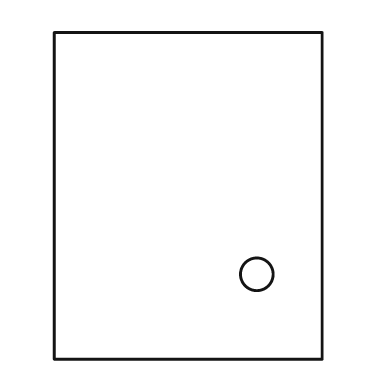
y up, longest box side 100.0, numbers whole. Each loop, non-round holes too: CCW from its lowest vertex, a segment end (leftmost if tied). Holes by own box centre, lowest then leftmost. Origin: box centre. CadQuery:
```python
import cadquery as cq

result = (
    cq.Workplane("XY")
    .moveTo(-41.0, -50.0)
    .lineTo(41.0, -50.0)
    .lineTo(41.0, 50.0)
    .lineTo(-41.0, 50.0)
    .close()
    .moveTo(21.0, -24.0)
    .circle(5.0)
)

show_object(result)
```